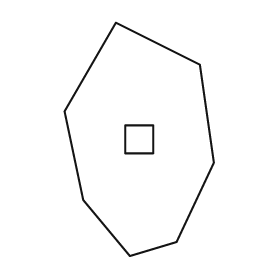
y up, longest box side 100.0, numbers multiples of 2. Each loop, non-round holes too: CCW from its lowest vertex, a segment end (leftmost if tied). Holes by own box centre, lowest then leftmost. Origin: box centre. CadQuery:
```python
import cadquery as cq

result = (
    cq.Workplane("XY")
    .moveTo(-4.0, -50.0)
    .lineTo(16.0, -44.0)
    .lineTo(32.0, -10.0)
    .lineTo(26.0, 32.0)
    .lineTo(-10.0, 50.0)
    .lineTo(-32.0, 12.0)
    .lineTo(-24.0, -26.0)
    .close()
    .moveTo(-6.0, -6.0)
    .lineTo(6.0, -6.0)
    .lineTo(6.0, 6.0)
    .lineTo(-6.0, 6.0)
    .close()
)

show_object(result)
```